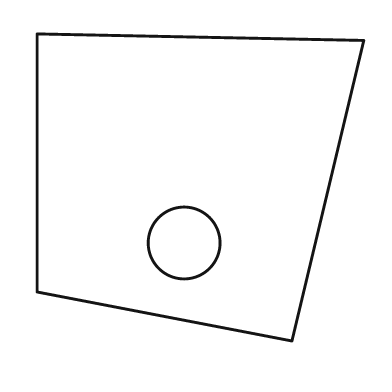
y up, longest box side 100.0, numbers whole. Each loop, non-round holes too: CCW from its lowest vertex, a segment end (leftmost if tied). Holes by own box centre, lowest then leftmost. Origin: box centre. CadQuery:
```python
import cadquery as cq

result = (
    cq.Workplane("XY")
    .moveTo(28.0, -47.0)
    .lineTo(50.0, 45.0)
    .lineTo(-50.0, 47.0)
    .lineTo(-50.0, -32.0)
    .close()
    .moveTo(-5.0, -17.0)
    .circle(11.0)
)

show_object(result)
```